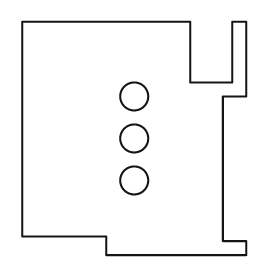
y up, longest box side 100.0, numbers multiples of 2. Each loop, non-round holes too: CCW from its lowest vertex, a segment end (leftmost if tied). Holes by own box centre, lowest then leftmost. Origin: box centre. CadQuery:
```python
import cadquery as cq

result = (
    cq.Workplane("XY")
    .moveTo(-12.0, -50.0)
    .lineTo(48.0, -50.0)
    .lineTo(48.0, -44.0)
    .lineTo(38.0, -44.0)
    .lineTo(38.0, 18.0)
    .lineTo(48.0, 18.0)
    .lineTo(48.0, 50.0)
    .lineTo(42.0, 50.0)
    .lineTo(42.0, 24.0)
    .lineTo(24.0, 24.0)
    .lineTo(24.0, 50.0)
    .lineTo(-48.0, 50.0)
    .lineTo(-48.0, -42.0)
    .lineTo(-12.0, -42.0)
    .close()
    .moveTo(0.0, -18.0)
    .circle(6.0)
    .moveTo(0.0, 0.0)
    .circle(6.0)
    .moveTo(0.0, 18.0)
    .circle(6.0)
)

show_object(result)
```